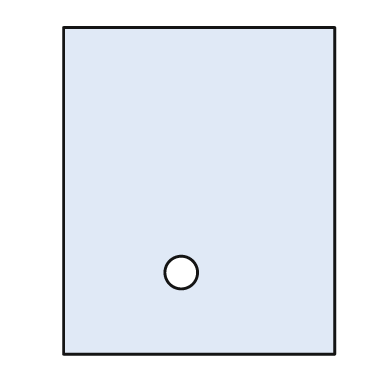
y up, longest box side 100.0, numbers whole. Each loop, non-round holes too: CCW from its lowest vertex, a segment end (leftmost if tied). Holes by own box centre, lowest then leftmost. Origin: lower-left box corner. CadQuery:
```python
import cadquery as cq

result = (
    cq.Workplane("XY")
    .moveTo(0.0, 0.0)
    .lineTo(83.0, 0.0)
    .lineTo(83.0, 100.0)
    .lineTo(0.0, 100.0)
    .close()
    .moveTo(36.0, 25.0)
    .circle(5.0)
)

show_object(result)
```